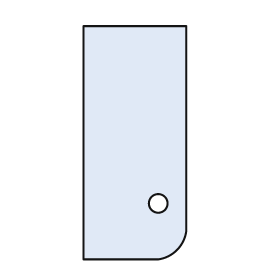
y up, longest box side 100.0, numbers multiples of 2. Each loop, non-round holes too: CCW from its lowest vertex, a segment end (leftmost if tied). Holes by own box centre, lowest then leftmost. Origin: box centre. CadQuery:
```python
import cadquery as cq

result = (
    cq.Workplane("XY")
    .moveTo(-22.0, -50.0)
    .lineTo(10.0, -50.0)
    .threePointArc((18.0, -46.0), (22.0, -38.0))
    .lineTo(22.0, 50.0)
    .lineTo(-22.0, 50.0)
    .close()
    .moveTo(10.0, -26.0)
    .circle(4.0)
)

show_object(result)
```